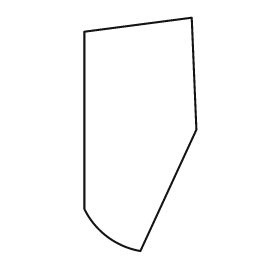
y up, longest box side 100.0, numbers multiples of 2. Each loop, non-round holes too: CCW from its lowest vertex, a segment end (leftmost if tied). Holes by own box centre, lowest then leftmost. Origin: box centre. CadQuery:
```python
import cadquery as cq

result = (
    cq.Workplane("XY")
    .moveTo(0.0, -50.0)
    .lineTo(24.0, 2.0)
    .lineTo(22.0, 50.0)
    .lineTo(-24.0, 44.0)
    .lineTo(-24.0, -32.0)
    .threePointArc((-14.0, -44.0), (0.0, -50.0))
    .close()
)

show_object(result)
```